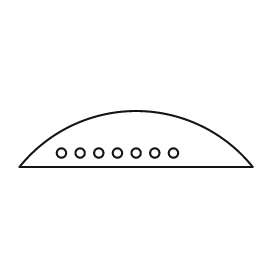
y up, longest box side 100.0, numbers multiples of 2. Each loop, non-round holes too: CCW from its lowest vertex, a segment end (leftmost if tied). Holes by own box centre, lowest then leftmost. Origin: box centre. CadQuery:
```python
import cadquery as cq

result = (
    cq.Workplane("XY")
    .moveTo(-50.0, -12.0)
    .lineTo(50.0, -12.0)
    .threePointArc((0.0, 12.0), (-50.0, -12.0))
    .close()
    .moveTo(-32.0, -6.0)
    .circle(2.0)
    .moveTo(-24.0, -6.0)
    .circle(2.0)
    .moveTo(-16.0, -6.0)
    .circle(2.0)
    .moveTo(-8.0, -6.0)
    .circle(2.0)
    .moveTo(0.0, -6.0)
    .circle(2.0)
    .moveTo(8.0, -6.0)
    .circle(2.0)
    .moveTo(16.0, -6.0)
    .circle(2.0)
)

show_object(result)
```